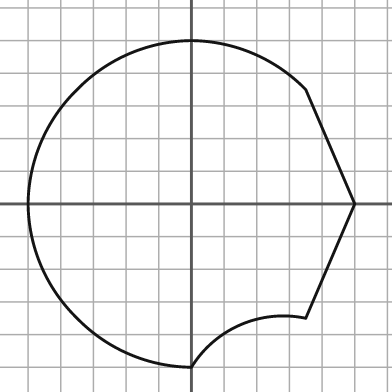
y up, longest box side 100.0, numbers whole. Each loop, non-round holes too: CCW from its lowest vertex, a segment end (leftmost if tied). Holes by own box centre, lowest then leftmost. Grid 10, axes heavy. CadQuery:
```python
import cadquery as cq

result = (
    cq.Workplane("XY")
    .moveTo(0.0, -50.0)
    .threePointArc((15.0, -37.0), (35.0, -35.0))
    .lineTo(50.0, 0.0)
    .lineTo(35.0, 35.0)
    .threePointArc((19.0, 46.0), (0.0, 50.0))
    .threePointArc((-19.0, 46.0), (-35.0, 35.0))
    .threePointArc((-46.0, 19.0), (-50.0, 0.0))
    .threePointArc((-46.0, -19.0), (-35.0, -35.0))
    .threePointArc((-19.0, -46.0), (0.0, -50.0))
    .close()
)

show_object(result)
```